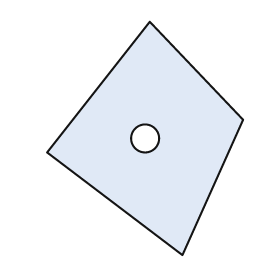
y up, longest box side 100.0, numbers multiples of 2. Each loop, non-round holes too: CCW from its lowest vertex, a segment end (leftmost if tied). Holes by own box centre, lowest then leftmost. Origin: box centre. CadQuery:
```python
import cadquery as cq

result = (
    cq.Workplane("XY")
    .moveTo(16.0, -50.0)
    .lineTo(42.0, 8.0)
    .lineTo(2.0, 50.0)
    .lineTo(-42.0, -6.0)
    .close()
    .moveTo(0.0, 0.0)
    .circle(6.0)
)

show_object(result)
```